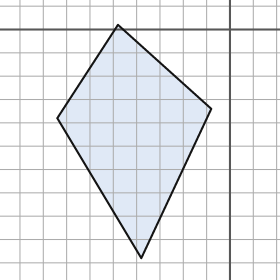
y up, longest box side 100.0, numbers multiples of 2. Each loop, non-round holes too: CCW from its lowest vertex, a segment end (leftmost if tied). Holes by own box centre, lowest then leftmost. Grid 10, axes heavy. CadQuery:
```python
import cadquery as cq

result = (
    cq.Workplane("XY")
    .moveTo(-38.0, -98.0)
    .lineTo(-8.0, -34.0)
    .lineTo(-48.0, 2.0)
    .lineTo(-74.0, -38.0)
    .close()
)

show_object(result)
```